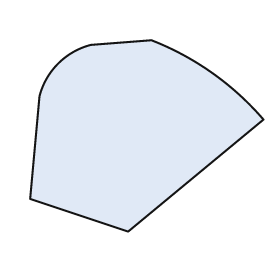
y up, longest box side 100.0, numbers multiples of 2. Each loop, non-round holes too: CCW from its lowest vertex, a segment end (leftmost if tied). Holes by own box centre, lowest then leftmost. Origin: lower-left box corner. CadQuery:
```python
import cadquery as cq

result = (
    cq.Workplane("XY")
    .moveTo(42.0, 0.0)
    .lineTo(100.0, 48.0)
    .threePointArc((78.0, 68.0), (52.0, 82.0))
    .lineTo(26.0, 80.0)
    .threePointArc((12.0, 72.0), (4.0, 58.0))
    .lineTo(0.0, 14.0)
    .close()
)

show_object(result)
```